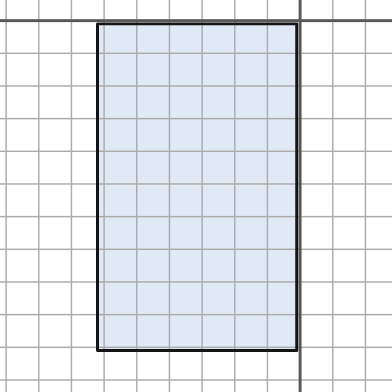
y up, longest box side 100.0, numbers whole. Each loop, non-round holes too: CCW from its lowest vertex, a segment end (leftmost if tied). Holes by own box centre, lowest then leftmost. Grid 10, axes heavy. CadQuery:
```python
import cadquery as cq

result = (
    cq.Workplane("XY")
    .moveTo(-62.0, -101.0)
    .lineTo(-1.0, -101.0)
    .lineTo(-1.0, -1.0)
    .lineTo(-62.0, -1.0)
    .close()
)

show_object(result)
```